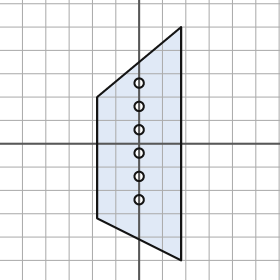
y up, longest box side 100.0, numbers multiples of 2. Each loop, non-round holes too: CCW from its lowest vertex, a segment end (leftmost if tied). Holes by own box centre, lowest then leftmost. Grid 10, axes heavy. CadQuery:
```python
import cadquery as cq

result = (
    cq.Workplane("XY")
    .moveTo(18.0, -50.0)
    .lineTo(18.0, 50.0)
    .lineTo(-18.0, 20.0)
    .lineTo(-18.0, -32.0)
    .close()
    .moveTo(0.0, -24.0)
    .circle(2.0)
    .moveTo(0.0, -14.0)
    .circle(2.0)
    .moveTo(0.0, -4.0)
    .circle(2.0)
    .moveTo(0.0, 6.0)
    .circle(2.0)
    .moveTo(0.0, 16.0)
    .circle(2.0)
    .moveTo(0.0, 26.0)
    .circle(2.0)
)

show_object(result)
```